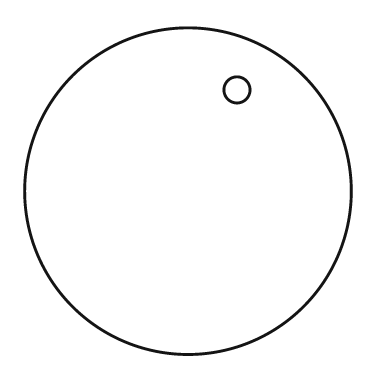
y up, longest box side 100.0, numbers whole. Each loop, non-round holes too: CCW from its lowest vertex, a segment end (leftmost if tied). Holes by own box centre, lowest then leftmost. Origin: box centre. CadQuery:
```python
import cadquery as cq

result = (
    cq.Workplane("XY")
    .moveTo(0.0, 0.0)
    .circle(50.0)
    .moveTo(15.0, 31.0)
    .circle(4.0)
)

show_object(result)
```